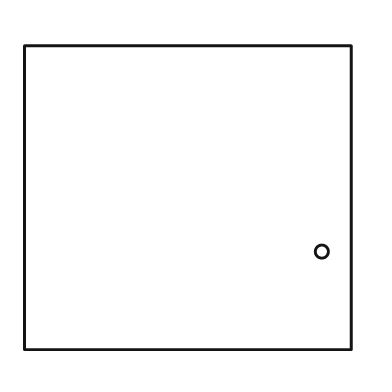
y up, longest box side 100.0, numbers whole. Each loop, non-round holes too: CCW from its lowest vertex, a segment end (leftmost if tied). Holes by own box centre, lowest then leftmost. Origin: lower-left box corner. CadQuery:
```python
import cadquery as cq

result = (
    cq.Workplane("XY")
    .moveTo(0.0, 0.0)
    .lineTo(100.0, 0.0)
    .lineTo(100.0, 93.0)
    .lineTo(0.0, 93.0)
    .close()
    .moveTo(91.0, 30.0)
    .circle(2.0)
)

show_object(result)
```